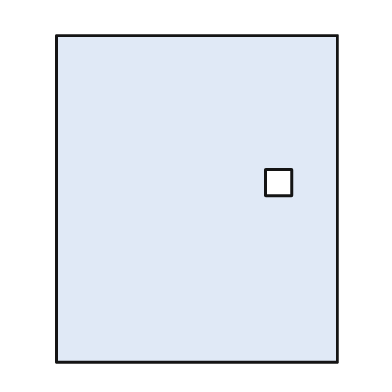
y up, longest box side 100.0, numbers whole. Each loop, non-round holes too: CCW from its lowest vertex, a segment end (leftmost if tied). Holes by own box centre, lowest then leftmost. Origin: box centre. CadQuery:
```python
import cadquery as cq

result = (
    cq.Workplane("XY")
    .moveTo(-43.0, -50.0)
    .lineTo(43.0, -50.0)
    .lineTo(43.0, 50.0)
    .lineTo(-43.0, 50.0)
    .close()
    .moveTo(21.0, 1.0)
    .lineTo(29.0, 1.0)
    .lineTo(29.0, 9.0)
    .lineTo(21.0, 9.0)
    .close()
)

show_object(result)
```